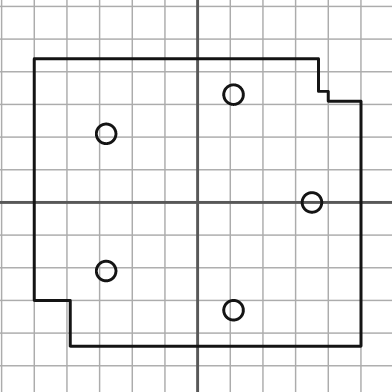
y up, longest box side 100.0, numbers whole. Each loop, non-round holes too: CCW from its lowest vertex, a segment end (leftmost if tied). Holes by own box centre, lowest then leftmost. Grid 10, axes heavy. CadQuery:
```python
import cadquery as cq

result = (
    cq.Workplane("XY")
    .moveTo(-39.0, -44.0)
    .lineTo(50.0, -44.0)
    .lineTo(50.0, 31.0)
    .lineTo(40.0, 31.0)
    .lineTo(40.0, 34.0)
    .lineTo(37.0, 34.0)
    .lineTo(37.0, 44.0)
    .lineTo(-50.0, 44.0)
    .lineTo(-50.0, -30.0)
    .lineTo(-39.0, -30.0)
    .close()
    .moveTo(11.0, -33.0)
    .circle(3.0)
    .moveTo(-28.0, -21.0)
    .circle(3.0)
    .moveTo(35.0, 0.0)
    .circle(3.0)
    .moveTo(-28.0, 21.0)
    .circle(3.0)
    .moveTo(11.0, 33.0)
    .circle(3.0)
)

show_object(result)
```